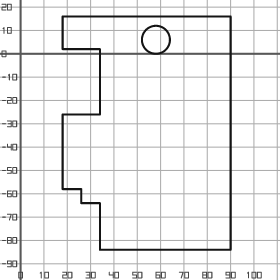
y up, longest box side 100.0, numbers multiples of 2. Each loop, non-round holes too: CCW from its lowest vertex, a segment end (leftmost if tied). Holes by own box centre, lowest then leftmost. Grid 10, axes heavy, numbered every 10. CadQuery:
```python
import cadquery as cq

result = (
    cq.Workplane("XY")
    .moveTo(34.0, -84.0)
    .lineTo(90.0, -84.0)
    .lineTo(90.0, 16.0)
    .lineTo(18.0, 16.0)
    .lineTo(18.0, 2.0)
    .lineTo(34.0, 2.0)
    .lineTo(34.0, -26.0)
    .lineTo(18.0, -26.0)
    .lineTo(18.0, -58.0)
    .lineTo(26.0, -58.0)
    .lineTo(26.0, -64.0)
    .lineTo(34.0, -64.0)
    .close()
    .moveTo(58.0, 6.0)
    .circle(6.0)
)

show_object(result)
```